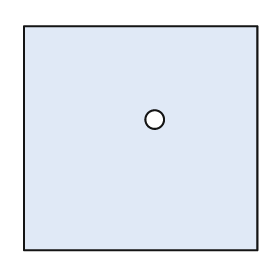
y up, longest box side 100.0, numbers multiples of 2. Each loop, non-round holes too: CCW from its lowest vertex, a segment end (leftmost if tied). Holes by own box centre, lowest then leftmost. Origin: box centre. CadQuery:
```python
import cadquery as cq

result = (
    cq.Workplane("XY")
    .moveTo(-50.0, -48.0)
    .lineTo(50.0, -48.0)
    .lineTo(50.0, 48.0)
    .lineTo(-50.0, 48.0)
    .close()
    .moveTo(6.0, 8.0)
    .circle(4.0)
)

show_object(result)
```